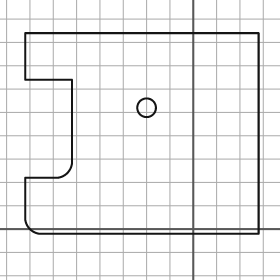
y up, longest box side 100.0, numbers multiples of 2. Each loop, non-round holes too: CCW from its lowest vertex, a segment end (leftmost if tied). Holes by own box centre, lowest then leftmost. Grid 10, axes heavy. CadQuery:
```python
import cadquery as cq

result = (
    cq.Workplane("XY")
    .moveTo(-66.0, -2.0)
    .lineTo(28.0, -2.0)
    .lineTo(28.0, 84.0)
    .lineTo(-72.0, 84.0)
    .lineTo(-72.0, 64.0)
    .lineTo(-52.0, 64.0)
    .lineTo(-52.0, 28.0)
    .threePointArc((-54.0, 24.0), (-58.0, 22.0))
    .lineTo(-72.0, 22.0)
    .lineTo(-72.0, 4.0)
    .threePointArc((-70.0, 0.0), (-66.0, -2.0))
    .close()
    .moveTo(-20.0, 52.0)
    .circle(4.0)
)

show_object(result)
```